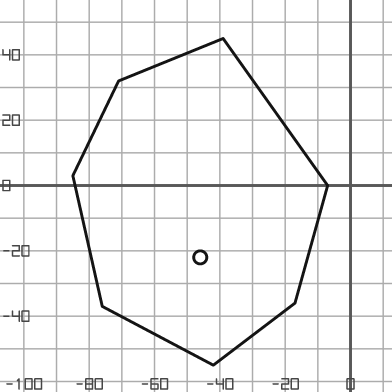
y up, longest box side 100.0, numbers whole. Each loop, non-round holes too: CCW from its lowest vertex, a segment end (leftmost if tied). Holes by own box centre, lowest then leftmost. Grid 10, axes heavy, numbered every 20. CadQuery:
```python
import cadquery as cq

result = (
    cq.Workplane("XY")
    .moveTo(-42.0, -55.0)
    .lineTo(-17.0, -36.0)
    .lineTo(-7.0, 0.0)
    .lineTo(-39.0, 45.0)
    .lineTo(-71.0, 32.0)
    .lineTo(-85.0, 3.0)
    .lineTo(-76.0, -37.0)
    .close()
    .moveTo(-46.0, -22.0)
    .circle(2.0)
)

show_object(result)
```